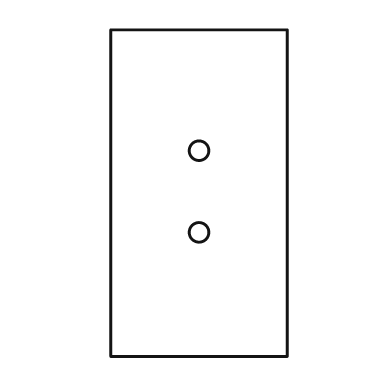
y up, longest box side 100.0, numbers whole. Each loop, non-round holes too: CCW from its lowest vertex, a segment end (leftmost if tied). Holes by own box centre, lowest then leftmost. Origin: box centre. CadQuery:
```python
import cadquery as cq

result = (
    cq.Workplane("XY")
    .moveTo(-27.0, -50.0)
    .lineTo(27.0, -50.0)
    .lineTo(27.0, 50.0)
    .lineTo(-27.0, 50.0)
    .close()
    .moveTo(0.0, -12.0)
    .circle(3.0)
    .moveTo(0.0, 13.0)
    .circle(3.0)
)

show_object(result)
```